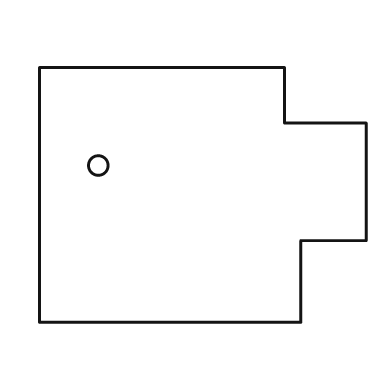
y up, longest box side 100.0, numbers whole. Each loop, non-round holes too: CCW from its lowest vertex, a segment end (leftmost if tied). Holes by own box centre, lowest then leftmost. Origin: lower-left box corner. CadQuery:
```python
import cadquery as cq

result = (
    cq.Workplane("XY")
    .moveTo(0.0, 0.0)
    .lineTo(80.0, 0.0)
    .lineTo(80.0, 25.0)
    .lineTo(100.0, 25.0)
    .lineTo(100.0, 61.0)
    .lineTo(75.0, 61.0)
    .lineTo(75.0, 78.0)
    .lineTo(0.0, 78.0)
    .close()
    .moveTo(18.0, 48.0)
    .circle(3.0)
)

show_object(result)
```